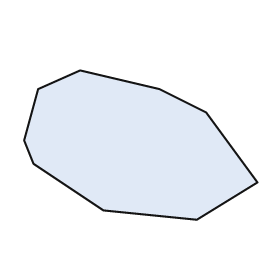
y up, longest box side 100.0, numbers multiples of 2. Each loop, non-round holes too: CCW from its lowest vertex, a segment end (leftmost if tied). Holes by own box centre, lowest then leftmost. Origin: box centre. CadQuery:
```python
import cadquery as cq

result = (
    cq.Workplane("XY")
    .moveTo(24.0, -32.0)
    .lineTo(50.0, -16.0)
    .lineTo(28.0, 14.0)
    .lineTo(8.0, 24.0)
    .lineTo(-26.0, 32.0)
    .lineTo(-44.0, 24.0)
    .lineTo(-50.0, 2.0)
    .lineTo(-46.0, -8.0)
    .lineTo(-16.0, -28.0)
    .close()
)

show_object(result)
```